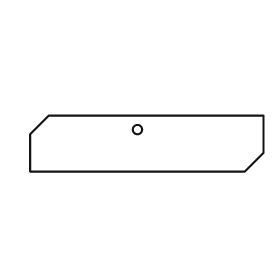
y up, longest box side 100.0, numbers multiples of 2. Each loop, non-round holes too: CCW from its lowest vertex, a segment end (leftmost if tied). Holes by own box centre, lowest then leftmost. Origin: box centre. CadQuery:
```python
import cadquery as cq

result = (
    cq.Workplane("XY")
    .moveTo(-50.0, -12.0)
    .lineTo(42.0, -12.0)
    .lineTo(50.0, -4.0)
    .lineTo(50.0, 12.0)
    .lineTo(-42.0, 12.0)
    .lineTo(-50.0, 4.0)
    .close()
    .moveTo(-4.0, 6.0)
    .circle(2.0)
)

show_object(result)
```